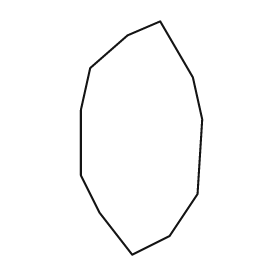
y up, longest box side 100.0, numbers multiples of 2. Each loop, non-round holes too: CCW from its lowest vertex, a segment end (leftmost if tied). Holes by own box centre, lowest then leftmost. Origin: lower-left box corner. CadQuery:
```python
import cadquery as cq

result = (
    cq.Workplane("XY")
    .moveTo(22.0, 0.0)
    .lineTo(38.0, 8.0)
    .lineTo(50.0, 26.0)
    .lineTo(52.0, 58.0)
    .lineTo(48.0, 76.0)
    .lineTo(34.0, 100.0)
    .lineTo(20.0, 94.0)
    .lineTo(4.0, 80.0)
    .lineTo(0.0, 62.0)
    .lineTo(0.0, 34.0)
    .lineTo(8.0, 18.0)
    .close()
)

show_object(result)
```